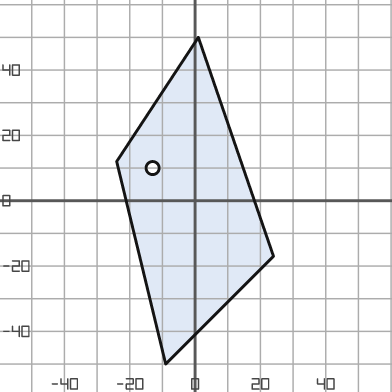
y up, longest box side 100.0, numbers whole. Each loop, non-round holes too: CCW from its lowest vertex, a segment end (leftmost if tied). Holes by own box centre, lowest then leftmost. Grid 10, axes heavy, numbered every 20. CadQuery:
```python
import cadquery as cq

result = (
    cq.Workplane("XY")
    .moveTo(-9.0, -50.0)
    .lineTo(24.0, -17.0)
    .lineTo(1.0, 50.0)
    .lineTo(-24.0, 12.0)
    .close()
    .moveTo(-13.0, 10.0)
    .circle(2.0)
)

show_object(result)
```